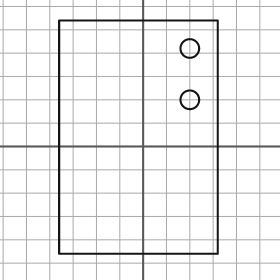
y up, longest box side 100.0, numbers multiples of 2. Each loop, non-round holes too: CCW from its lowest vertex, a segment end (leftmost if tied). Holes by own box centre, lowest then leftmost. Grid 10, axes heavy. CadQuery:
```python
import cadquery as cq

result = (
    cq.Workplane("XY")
    .moveTo(-36.0, -46.0)
    .lineTo(32.0, -46.0)
    .lineTo(32.0, 54.0)
    .lineTo(-36.0, 54.0)
    .close()
    .moveTo(20.0, 20.0)
    .circle(4.0)
    .moveTo(20.0, 42.0)
    .circle(4.0)
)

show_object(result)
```